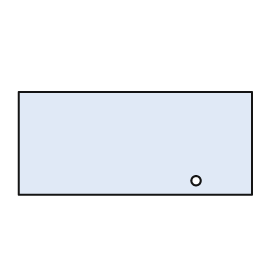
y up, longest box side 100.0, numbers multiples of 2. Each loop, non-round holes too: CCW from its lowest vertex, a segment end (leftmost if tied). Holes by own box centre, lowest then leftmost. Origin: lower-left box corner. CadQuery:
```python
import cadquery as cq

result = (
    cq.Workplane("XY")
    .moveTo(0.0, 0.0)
    .lineTo(100.0, 0.0)
    .lineTo(100.0, 44.0)
    .lineTo(0.0, 44.0)
    .close()
    .moveTo(76.0, 6.0)
    .circle(2.0)
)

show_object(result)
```